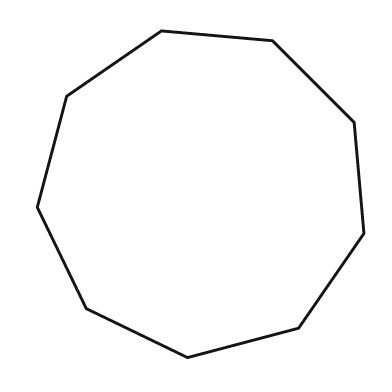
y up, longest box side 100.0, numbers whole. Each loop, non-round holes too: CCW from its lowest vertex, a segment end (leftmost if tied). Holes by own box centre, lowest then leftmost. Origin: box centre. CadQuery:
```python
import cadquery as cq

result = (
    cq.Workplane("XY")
    .moveTo(-4.0, -50.0)
    .lineTo(30.0, -41.0)
    .lineTo(50.0, -12.0)
    .lineTo(47.0, 22.0)
    .lineTo(22.0, 47.0)
    .lineTo(-12.0, 50.0)
    .lineTo(-41.0, 30.0)
    .lineTo(-50.0, -4.0)
    .lineTo(-35.0, -35.0)
    .close()
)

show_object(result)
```